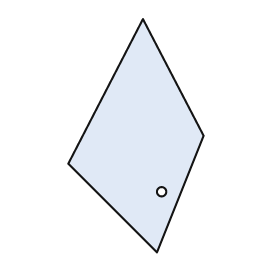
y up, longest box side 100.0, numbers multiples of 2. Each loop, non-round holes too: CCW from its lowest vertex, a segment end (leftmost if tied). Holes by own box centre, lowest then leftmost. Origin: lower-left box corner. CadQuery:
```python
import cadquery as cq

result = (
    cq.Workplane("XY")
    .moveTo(38.0, 0.0)
    .lineTo(58.0, 50.0)
    .lineTo(32.0, 100.0)
    .lineTo(0.0, 38.0)
    .close()
    .moveTo(40.0, 26.0)
    .circle(2.0)
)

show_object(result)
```